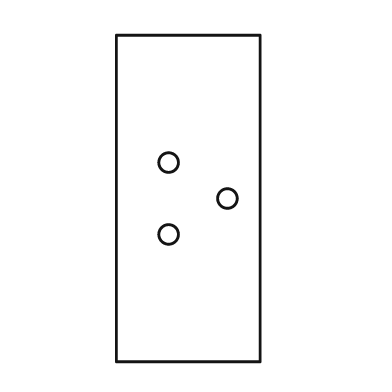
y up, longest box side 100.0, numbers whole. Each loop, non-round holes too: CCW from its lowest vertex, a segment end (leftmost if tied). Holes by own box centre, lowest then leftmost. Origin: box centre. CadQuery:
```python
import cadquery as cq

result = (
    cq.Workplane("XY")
    .moveTo(-22.0, -50.0)
    .lineTo(22.0, -50.0)
    .lineTo(22.0, 50.0)
    .lineTo(-22.0, 50.0)
    .close()
    .moveTo(-6.0, -11.0)
    .circle(3.0)
    .moveTo(12.0, 0.0)
    .circle(3.0)
    .moveTo(-6.0, 11.0)
    .circle(3.0)
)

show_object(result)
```